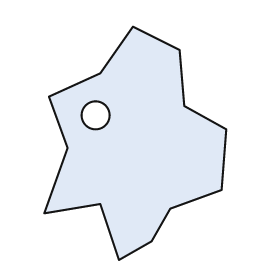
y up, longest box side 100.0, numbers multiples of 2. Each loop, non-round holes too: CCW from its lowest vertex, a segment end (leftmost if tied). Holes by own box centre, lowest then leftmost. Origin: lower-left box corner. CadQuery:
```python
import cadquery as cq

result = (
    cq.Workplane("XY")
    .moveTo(32.0, 0.0)
    .lineTo(46.0, 8.0)
    .lineTo(54.0, 22.0)
    .lineTo(76.0, 30.0)
    .lineTo(78.0, 56.0)
    .lineTo(60.0, 66.0)
    .lineTo(58.0, 90.0)
    .lineTo(38.0, 100.0)
    .lineTo(24.0, 80.0)
    .lineTo(2.0, 70.0)
    .lineTo(10.0, 48.0)
    .lineTo(0.0, 20.0)
    .lineTo(24.0, 24.0)
    .close()
    .moveTo(22.0, 62.0)
    .circle(6.0)
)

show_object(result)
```